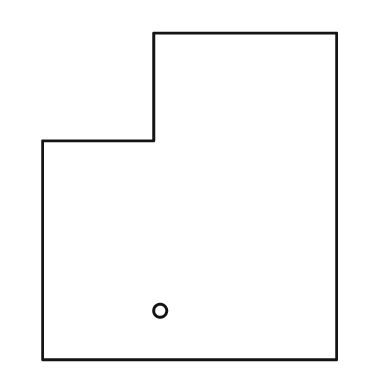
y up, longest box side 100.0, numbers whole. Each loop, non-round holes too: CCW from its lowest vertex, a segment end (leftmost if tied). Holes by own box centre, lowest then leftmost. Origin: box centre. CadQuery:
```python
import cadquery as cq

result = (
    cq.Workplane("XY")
    .moveTo(-45.0, -50.0)
    .lineTo(45.0, -50.0)
    .lineTo(45.0, 50.0)
    .lineTo(-11.0, 50.0)
    .lineTo(-11.0, 17.0)
    .lineTo(-45.0, 17.0)
    .close()
    .moveTo(-9.0, -35.0)
    .circle(2.0)
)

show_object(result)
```